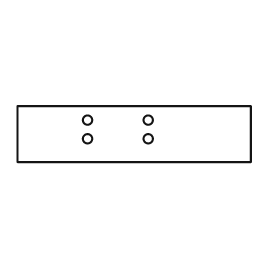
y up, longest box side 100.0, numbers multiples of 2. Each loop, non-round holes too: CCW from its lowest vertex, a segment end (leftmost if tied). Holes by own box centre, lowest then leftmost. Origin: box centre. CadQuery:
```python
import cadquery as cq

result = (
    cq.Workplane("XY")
    .moveTo(-50.0, -12.0)
    .lineTo(50.0, -12.0)
    .lineTo(50.0, 12.0)
    .lineTo(-50.0, 12.0)
    .close()
    .moveTo(-20.0, -2.0)
    .circle(2.0)
    .moveTo(6.0, -2.0)
    .circle(2.0)
    .moveTo(-20.0, 6.0)
    .circle(2.0)
    .moveTo(6.0, 6.0)
    .circle(2.0)
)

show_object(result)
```